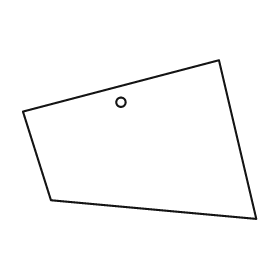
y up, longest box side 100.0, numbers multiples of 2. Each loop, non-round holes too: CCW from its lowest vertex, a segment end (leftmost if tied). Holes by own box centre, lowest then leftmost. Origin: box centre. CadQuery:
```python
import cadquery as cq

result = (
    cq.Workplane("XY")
    .moveTo(50.0, -34.0)
    .lineTo(34.0, 34.0)
    .lineTo(-50.0, 12.0)
    .lineTo(-38.0, -26.0)
    .close()
    .moveTo(-8.0, 16.0)
    .circle(2.0)
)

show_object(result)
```